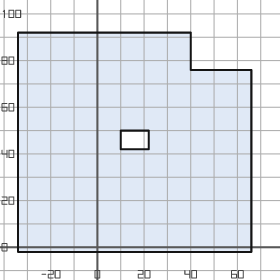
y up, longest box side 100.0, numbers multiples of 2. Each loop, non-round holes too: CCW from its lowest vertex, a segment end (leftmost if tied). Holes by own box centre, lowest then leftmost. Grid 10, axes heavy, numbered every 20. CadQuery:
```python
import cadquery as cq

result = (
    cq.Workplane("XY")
    .moveTo(-34.0, -2.0)
    .lineTo(66.0, -2.0)
    .lineTo(66.0, 76.0)
    .lineTo(40.0, 76.0)
    .lineTo(40.0, 92.0)
    .lineTo(-34.0, 92.0)
    .close()
    .moveTo(10.0, 42.0)
    .lineTo(22.0, 42.0)
    .lineTo(22.0, 50.0)
    .lineTo(10.0, 50.0)
    .close()
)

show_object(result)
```